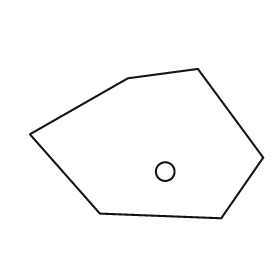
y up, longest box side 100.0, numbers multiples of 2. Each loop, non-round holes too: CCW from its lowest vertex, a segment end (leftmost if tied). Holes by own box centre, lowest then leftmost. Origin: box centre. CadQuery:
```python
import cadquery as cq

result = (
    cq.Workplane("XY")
    .moveTo(32.0, -32.0)
    .lineTo(50.0, -6.0)
    .lineTo(22.0, 32.0)
    .lineTo(-8.0, 28.0)
    .lineTo(-50.0, 4.0)
    .lineTo(-20.0, -30.0)
    .close()
    .moveTo(8.0, -12.0)
    .circle(4.0)
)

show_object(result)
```